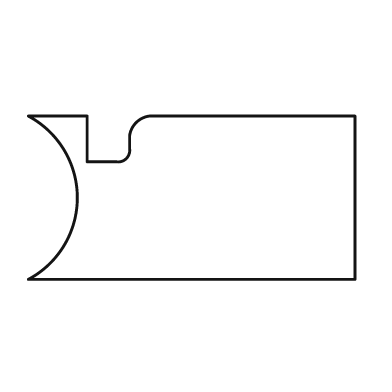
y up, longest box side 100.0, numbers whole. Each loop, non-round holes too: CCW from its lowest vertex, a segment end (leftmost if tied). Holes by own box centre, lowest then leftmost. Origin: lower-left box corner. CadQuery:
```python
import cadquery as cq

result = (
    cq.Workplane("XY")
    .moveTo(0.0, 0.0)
    .lineTo(100.0, 0.0)
    .lineTo(100.0, 50.0)
    .lineTo(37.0, 50.0)
    .threePointArc((33.0, 48.0), (31.0, 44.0))
    .lineTo(31.0, 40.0)
    .threePointArc((30.0, 37.0), (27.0, 36.0))
    .lineTo(18.0, 36.0)
    .lineTo(18.0, 50.0)
    .lineTo(0.0, 50.0)
    .threePointArc((15.0, 25.0), (0.0, 0.0))
    .close()
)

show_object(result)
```